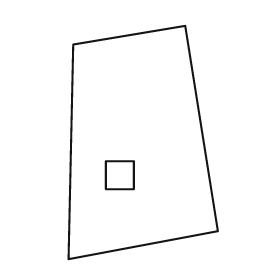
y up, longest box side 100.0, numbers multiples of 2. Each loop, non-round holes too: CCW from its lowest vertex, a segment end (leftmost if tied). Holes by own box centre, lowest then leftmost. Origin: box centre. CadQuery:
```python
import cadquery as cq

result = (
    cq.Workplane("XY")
    .moveTo(-32.0, -50.0)
    .lineTo(32.0, -38.0)
    .lineTo(18.0, 50.0)
    .lineTo(-30.0, 42.0)
    .close()
    .moveTo(-16.0, -20.0)
    .lineTo(-4.0, -20.0)
    .lineTo(-4.0, -8.0)
    .lineTo(-16.0, -8.0)
    .close()
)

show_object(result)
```